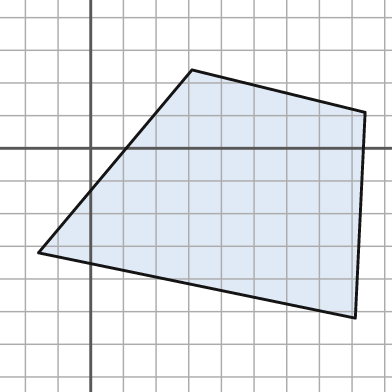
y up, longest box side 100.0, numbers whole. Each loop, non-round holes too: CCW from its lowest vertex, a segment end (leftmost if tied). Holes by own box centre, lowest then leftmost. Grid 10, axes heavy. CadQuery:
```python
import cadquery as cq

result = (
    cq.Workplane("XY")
    .moveTo(81.0, -52.0)
    .lineTo(84.0, 11.0)
    .lineTo(31.0, 24.0)
    .lineTo(-16.0, -32.0)
    .close()
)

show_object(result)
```